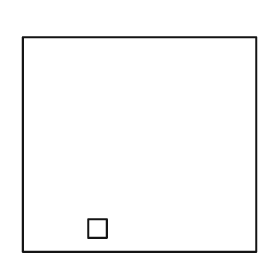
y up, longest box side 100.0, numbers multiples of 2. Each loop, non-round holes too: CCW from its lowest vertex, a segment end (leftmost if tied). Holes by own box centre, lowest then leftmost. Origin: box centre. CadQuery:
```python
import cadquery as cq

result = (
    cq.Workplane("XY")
    .moveTo(-50.0, -46.0)
    .lineTo(50.0, -46.0)
    .lineTo(50.0, 46.0)
    .lineTo(-50.0, 46.0)
    .close()
    .moveTo(-22.0, -40.0)
    .lineTo(-14.0, -40.0)
    .lineTo(-14.0, -32.0)
    .lineTo(-22.0, -32.0)
    .close()
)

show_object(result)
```